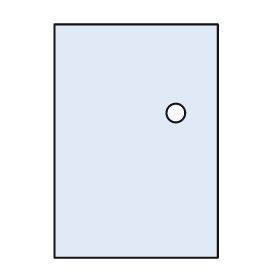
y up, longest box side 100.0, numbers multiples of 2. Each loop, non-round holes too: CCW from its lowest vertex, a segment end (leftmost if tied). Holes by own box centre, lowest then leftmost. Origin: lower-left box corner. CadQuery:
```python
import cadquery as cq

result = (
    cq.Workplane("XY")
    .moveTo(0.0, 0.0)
    .lineTo(70.0, 0.0)
    .lineTo(70.0, 100.0)
    .lineTo(0.0, 100.0)
    .close()
    .moveTo(52.0, 62.0)
    .circle(4.0)
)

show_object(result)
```